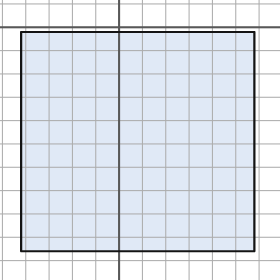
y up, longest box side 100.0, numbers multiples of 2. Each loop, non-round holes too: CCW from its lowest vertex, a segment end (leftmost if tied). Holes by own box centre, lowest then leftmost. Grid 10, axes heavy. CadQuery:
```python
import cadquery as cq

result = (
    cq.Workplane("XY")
    .moveTo(-42.0, -96.0)
    .lineTo(58.0, -96.0)
    .lineTo(58.0, -2.0)
    .lineTo(-42.0, -2.0)
    .close()
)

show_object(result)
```